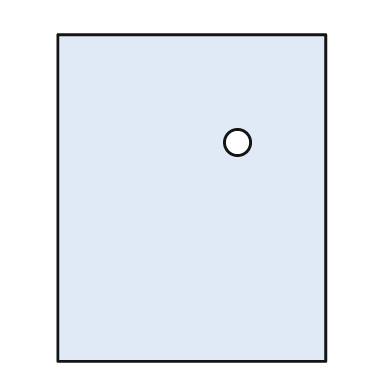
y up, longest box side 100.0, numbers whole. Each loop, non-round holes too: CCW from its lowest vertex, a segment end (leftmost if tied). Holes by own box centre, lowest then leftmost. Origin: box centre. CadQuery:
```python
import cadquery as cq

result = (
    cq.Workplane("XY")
    .moveTo(-41.0, -50.0)
    .lineTo(41.0, -50.0)
    .lineTo(41.0, 50.0)
    .lineTo(-41.0, 50.0)
    .close()
    .moveTo(14.0, 17.0)
    .circle(4.0)
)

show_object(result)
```